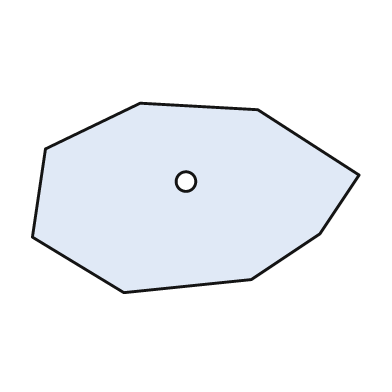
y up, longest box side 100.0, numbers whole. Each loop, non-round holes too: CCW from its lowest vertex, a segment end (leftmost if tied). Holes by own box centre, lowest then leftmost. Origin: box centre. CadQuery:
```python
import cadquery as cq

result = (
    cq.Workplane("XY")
    .moveTo(-22.0, -29.0)
    .lineTo(17.0, -25.0)
    .lineTo(38.0, -11.0)
    .lineTo(50.0, 7.0)
    .lineTo(19.0, 27.0)
    .lineTo(-17.0, 29.0)
    .lineTo(-46.0, 15.0)
    .lineTo(-50.0, -12.0)
    .close()
    .moveTo(-3.0, 5.0)
    .circle(3.0)
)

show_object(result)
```